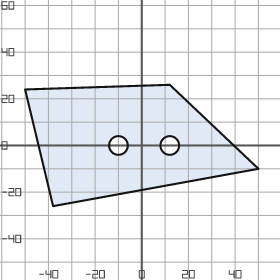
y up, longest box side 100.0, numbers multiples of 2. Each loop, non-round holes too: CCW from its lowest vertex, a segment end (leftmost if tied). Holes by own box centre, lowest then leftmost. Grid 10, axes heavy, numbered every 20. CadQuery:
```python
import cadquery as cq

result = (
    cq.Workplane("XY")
    .moveTo(-38.0, -26.0)
    .lineTo(50.0, -10.0)
    .lineTo(12.0, 26.0)
    .lineTo(-50.0, 24.0)
    .close()
    .moveTo(-10.0, 0.0)
    .circle(4.0)
    .moveTo(12.0, 0.0)
    .circle(4.0)
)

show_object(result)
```